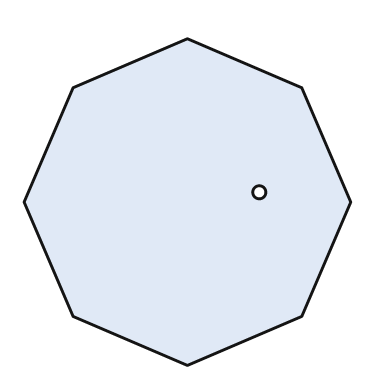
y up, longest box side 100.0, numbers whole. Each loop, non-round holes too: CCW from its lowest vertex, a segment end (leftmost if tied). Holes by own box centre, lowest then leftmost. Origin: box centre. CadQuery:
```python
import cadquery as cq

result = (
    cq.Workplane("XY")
    .moveTo(0.0, -50.0)
    .lineTo(35.0, -35.0)
    .lineTo(50.0, 0.0)
    .lineTo(35.0, 35.0)
    .lineTo(0.0, 50.0)
    .lineTo(-35.0, 35.0)
    .lineTo(-50.0, 0.0)
    .lineTo(-35.0, -35.0)
    .close()
    .moveTo(22.0, 3.0)
    .circle(2.0)
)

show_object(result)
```